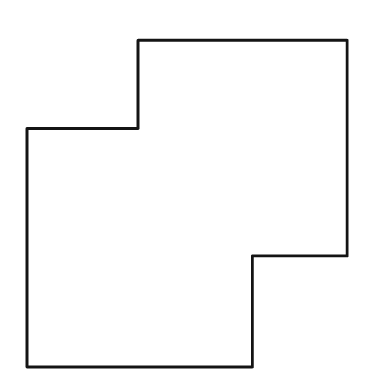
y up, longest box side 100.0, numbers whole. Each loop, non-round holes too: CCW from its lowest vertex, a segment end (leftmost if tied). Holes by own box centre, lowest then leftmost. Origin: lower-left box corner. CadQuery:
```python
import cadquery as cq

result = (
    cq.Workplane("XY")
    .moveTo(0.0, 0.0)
    .lineTo(69.0, 0.0)
    .lineTo(69.0, 34.0)
    .lineTo(98.0, 34.0)
    .lineTo(98.0, 100.0)
    .lineTo(34.0, 100.0)
    .lineTo(34.0, 73.0)
    .lineTo(0.0, 73.0)
    .close()
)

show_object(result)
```